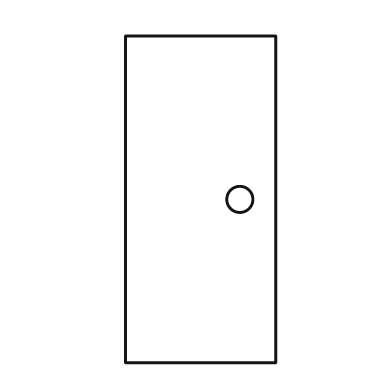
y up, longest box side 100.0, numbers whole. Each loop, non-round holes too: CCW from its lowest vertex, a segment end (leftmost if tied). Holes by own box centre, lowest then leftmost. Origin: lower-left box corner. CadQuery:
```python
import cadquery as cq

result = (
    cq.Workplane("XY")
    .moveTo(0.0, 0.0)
    .lineTo(46.0, 0.0)
    .lineTo(46.0, 100.0)
    .lineTo(0.0, 100.0)
    .close()
    .moveTo(35.0, 50.0)
    .circle(4.0)
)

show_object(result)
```